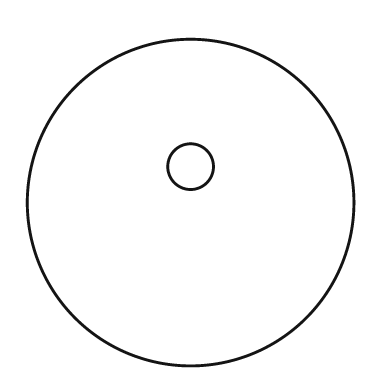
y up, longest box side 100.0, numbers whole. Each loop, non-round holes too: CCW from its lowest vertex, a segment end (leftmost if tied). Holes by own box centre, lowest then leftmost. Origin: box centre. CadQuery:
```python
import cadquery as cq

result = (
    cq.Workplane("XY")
    .moveTo(0.0, 0.0)
    .circle(50.0)
    .moveTo(0.0, 11.0)
    .circle(7.0)
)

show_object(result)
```